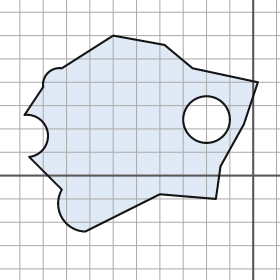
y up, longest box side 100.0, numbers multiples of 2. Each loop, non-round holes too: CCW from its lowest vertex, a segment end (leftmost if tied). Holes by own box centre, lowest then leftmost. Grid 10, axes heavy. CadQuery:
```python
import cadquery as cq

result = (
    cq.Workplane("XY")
    .moveTo(-72.0, -24.0)
    .lineTo(-40.0, -8.0)
    .lineTo(-16.0, -10.0)
    .lineTo(-14.0, 4.0)
    .lineTo(-4.0, 22.0)
    .lineTo(2.0, 40.0)
    .lineTo(-26.0, 46.0)
    .lineTo(-38.0, 56.0)
    .lineTo(-60.0, 60.0)
    .lineTo(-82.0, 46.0)
    .threePointArc((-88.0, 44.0), (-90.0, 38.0))
    .lineTo(-98.0, 26.0)
    .threePointArc((-88.0, 18.0), (-96.0, 8.0))
    .lineTo(-82.0, -6.0)
    .threePointArc((-82.0, -18.0), (-72.0, -24.0))
    .close()
    .moveTo(-20.0, 24.0)
    .circle(10.0)
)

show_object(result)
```